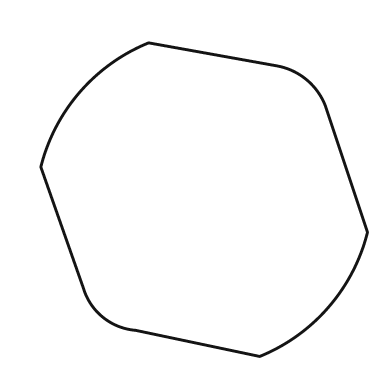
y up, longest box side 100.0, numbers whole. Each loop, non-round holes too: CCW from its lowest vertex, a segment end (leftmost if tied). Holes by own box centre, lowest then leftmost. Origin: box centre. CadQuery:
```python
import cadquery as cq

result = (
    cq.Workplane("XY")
    .moveTo(17.0, -48.0)
    .threePointArc((38.0, -33.0), (50.0, -10.0))
    .lineTo(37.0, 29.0)
    .threePointArc((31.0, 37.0), (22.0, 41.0))
    .lineTo(-17.0, 48.0)
    .threePointArc((-38.0, 33.0), (-50.0, 10.0))
    .lineTo(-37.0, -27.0)
    .threePointArc((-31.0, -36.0), (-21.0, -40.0))
    .close()
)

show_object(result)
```